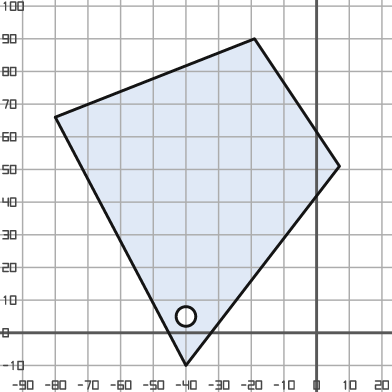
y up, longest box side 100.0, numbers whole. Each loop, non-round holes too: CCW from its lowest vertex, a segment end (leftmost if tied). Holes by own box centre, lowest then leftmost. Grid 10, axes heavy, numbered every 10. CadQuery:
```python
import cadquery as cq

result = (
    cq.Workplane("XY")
    .moveTo(-40.0, -10.0)
    .lineTo(7.0, 51.0)
    .lineTo(-19.0, 90.0)
    .lineTo(-80.0, 66.0)
    .close()
    .moveTo(-40.0, 5.0)
    .circle(3.0)
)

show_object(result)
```